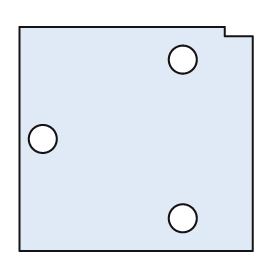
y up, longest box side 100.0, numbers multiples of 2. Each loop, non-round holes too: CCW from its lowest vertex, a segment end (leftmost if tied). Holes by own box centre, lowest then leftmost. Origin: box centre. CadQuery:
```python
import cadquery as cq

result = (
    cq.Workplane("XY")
    .moveTo(-50.0, -48.0)
    .lineTo(50.0, -48.0)
    .lineTo(50.0, 44.0)
    .lineTo(38.0, 44.0)
    .lineTo(38.0, 48.0)
    .lineTo(-50.0, 48.0)
    .close()
    .moveTo(20.0, -34.0)
    .circle(6.0)
    .moveTo(-40.0, 0.0)
    .circle(6.0)
    .moveTo(20.0, 34.0)
    .circle(6.0)
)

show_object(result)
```